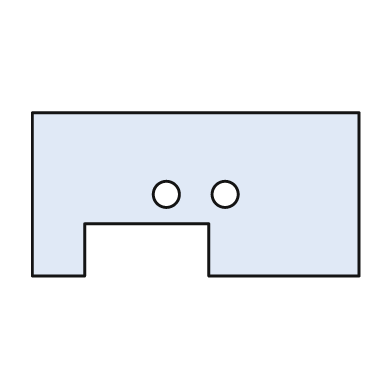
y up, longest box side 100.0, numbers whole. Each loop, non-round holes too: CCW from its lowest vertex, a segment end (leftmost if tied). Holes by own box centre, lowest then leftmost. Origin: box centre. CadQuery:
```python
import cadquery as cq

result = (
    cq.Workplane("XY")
    .moveTo(-50.0, -25.0)
    .lineTo(-34.0, -25.0)
    .lineTo(-34.0, -9.0)
    .lineTo(4.0, -9.0)
    .lineTo(4.0, -25.0)
    .lineTo(50.0, -25.0)
    .lineTo(50.0, 25.0)
    .lineTo(-50.0, 25.0)
    .close()
    .moveTo(-9.0, 0.0)
    .circle(4.0)
    .moveTo(9.0, 0.0)
    .circle(4.0)
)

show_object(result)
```